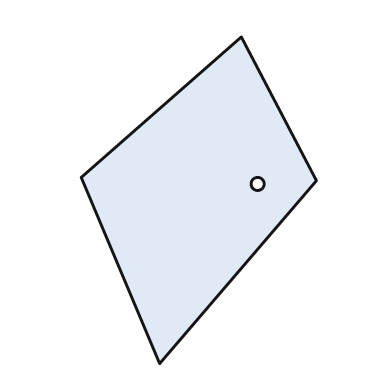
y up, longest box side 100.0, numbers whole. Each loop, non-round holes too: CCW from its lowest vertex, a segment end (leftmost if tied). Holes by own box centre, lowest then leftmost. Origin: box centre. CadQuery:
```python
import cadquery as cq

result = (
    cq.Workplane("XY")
    .moveTo(-12.0, -50.0)
    .lineTo(36.0, 6.0)
    .lineTo(13.0, 50.0)
    .lineTo(-36.0, 7.0)
    .close()
    .moveTo(18.0, 5.0)
    .circle(2.0)
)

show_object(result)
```